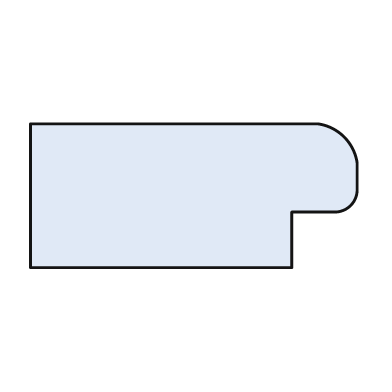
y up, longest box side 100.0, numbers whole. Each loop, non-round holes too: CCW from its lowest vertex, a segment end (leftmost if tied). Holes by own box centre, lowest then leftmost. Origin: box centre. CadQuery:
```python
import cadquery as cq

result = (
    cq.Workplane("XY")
    .moveTo(-50.0, -22.0)
    .lineTo(30.0, -22.0)
    .lineTo(30.0, -5.0)
    .lineTo(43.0, -5.0)
    .threePointArc((48.0, -3.0), (50.0, 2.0))
    .lineTo(50.0, 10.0)
    .threePointArc((46.0, 18.0), (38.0, 22.0))
    .lineTo(-50.0, 22.0)
    .close()
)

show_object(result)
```